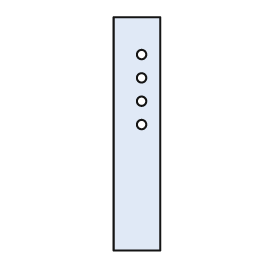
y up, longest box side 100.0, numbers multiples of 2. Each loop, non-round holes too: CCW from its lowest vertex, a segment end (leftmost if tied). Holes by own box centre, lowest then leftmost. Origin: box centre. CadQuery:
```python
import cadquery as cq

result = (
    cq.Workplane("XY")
    .moveTo(-10.0, -50.0)
    .lineTo(10.0, -50.0)
    .lineTo(10.0, 50.0)
    .lineTo(-10.0, 50.0)
    .close()
    .moveTo(2.0, 4.0)
    .circle(2.0)
    .moveTo(2.0, 14.0)
    .circle(2.0)
    .moveTo(2.0, 24.0)
    .circle(2.0)
    .moveTo(2.0, 34.0)
    .circle(2.0)
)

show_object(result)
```